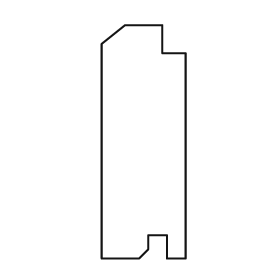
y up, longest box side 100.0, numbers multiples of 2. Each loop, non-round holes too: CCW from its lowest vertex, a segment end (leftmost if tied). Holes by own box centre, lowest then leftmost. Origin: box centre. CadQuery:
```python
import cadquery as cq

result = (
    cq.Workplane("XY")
    .moveTo(-18.0, -50.0)
    .lineTo(-2.0, -50.0)
    .lineTo(2.0, -46.0)
    .lineTo(2.0, -40.0)
    .lineTo(10.0, -40.0)
    .lineTo(10.0, -50.0)
    .lineTo(18.0, -50.0)
    .lineTo(18.0, 38.0)
    .lineTo(8.0, 38.0)
    .lineTo(8.0, 50.0)
    .lineTo(-8.0, 50.0)
    .lineTo(-18.0, 42.0)
    .close()
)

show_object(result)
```